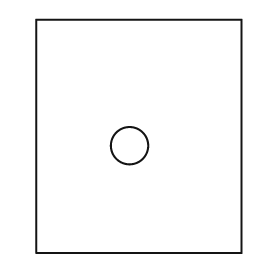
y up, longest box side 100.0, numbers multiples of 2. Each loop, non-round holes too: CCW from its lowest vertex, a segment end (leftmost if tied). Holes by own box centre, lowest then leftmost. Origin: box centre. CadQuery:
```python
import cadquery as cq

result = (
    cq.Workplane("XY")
    .moveTo(-44.0, -50.0)
    .lineTo(44.0, -50.0)
    .lineTo(44.0, 50.0)
    .lineTo(-44.0, 50.0)
    .close()
    .moveTo(-4.0, -4.0)
    .circle(8.0)
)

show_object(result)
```